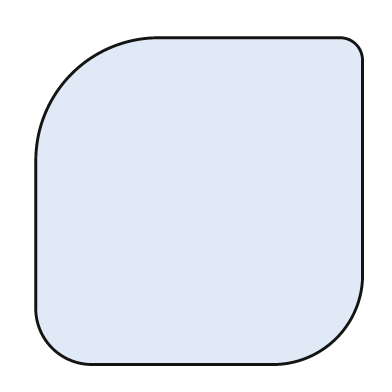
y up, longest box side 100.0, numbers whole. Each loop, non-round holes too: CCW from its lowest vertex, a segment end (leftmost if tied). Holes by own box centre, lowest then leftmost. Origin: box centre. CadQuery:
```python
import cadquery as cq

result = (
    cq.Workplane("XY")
    .moveTo(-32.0, -50.0)
    .lineTo(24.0, -50.0)
    .threePointArc((42.0, -42.0), (50.0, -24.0))
    .lineTo(50.0, 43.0)
    .threePointArc((48.0, 48.0), (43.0, 50.0))
    .lineTo(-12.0, 50.0)
    .threePointArc((-39.0, 39.0), (-50.0, 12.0))
    .lineTo(-50.0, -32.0)
    .threePointArc((-45.0, -45.0), (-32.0, -50.0))
    .close()
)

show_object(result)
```